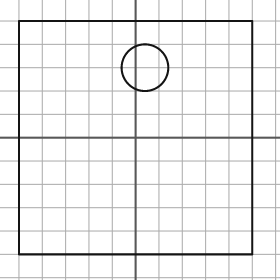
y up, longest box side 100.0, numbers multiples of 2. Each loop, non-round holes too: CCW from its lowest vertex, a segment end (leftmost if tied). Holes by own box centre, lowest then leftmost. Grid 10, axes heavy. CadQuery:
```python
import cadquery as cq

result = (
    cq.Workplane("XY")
    .moveTo(-50.0, -50.0)
    .lineTo(50.0, -50.0)
    .lineTo(50.0, 50.0)
    .lineTo(-50.0, 50.0)
    .close()
    .moveTo(4.0, 30.0)
    .circle(10.0)
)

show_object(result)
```